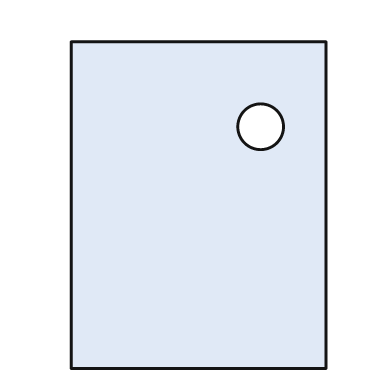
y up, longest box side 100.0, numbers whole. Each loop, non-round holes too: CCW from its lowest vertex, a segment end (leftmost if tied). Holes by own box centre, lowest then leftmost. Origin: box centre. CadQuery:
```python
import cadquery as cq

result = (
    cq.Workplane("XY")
    .moveTo(-39.0, -50.0)
    .lineTo(39.0, -50.0)
    .lineTo(39.0, 50.0)
    .lineTo(-39.0, 50.0)
    .close()
    .moveTo(19.0, 24.0)
    .circle(7.0)
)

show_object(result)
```